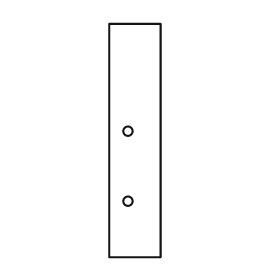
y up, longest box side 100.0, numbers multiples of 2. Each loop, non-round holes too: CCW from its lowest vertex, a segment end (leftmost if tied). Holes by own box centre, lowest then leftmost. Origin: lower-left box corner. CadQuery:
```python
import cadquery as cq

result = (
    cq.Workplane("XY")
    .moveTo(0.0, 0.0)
    .lineTo(22.0, 0.0)
    .lineTo(22.0, 100.0)
    .lineTo(0.0, 100.0)
    .close()
    .moveTo(8.0, 24.0)
    .circle(2.0)
    .moveTo(8.0, 54.0)
    .circle(2.0)
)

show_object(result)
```